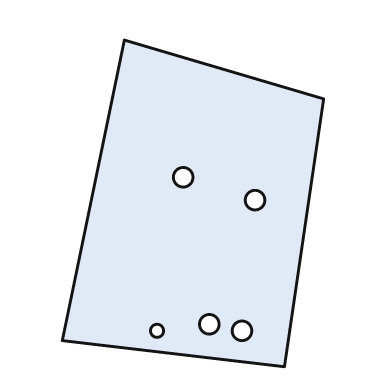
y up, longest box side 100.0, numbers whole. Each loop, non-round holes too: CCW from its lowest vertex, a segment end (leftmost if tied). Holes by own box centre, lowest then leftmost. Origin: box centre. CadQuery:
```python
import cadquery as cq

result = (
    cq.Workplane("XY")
    .moveTo(28.0, -50.0)
    .lineTo(40.0, 32.0)
    .lineTo(-21.0, 50.0)
    .lineTo(-40.0, -42.0)
    .close()
    .moveTo(-11.0, -39.0)
    .circle(2.0)
    .moveTo(15.0, -39.0)
    .circle(3.0)
    .moveTo(5.0, -37.0)
    .circle(3.0)
    .moveTo(19.0, 1.0)
    .circle(3.0)
    .moveTo(-3.0, 8.0)
    .circle(3.0)
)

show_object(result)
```